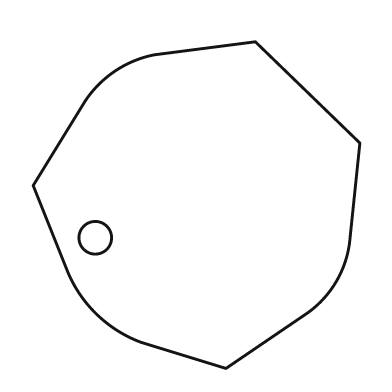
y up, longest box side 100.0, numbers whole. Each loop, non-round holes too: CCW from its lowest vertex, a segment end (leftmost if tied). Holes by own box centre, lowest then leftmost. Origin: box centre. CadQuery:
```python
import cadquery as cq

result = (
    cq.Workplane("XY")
    .moveTo(9.0, -50.0)
    .lineTo(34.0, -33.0)
    .threePointArc((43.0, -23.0), (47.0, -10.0))
    .lineTo(50.0, 19.0)
    .lineTo(18.0, 50.0)
    .lineTo(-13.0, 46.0)
    .threePointArc((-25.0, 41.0), (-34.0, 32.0))
    .lineTo(-50.0, 6.0)
    .lineTo(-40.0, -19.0)
    .threePointArc((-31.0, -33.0), (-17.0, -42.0))
    .close()
    .moveTo(-31.0, -10.0)
    .circle(5.0)
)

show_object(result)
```